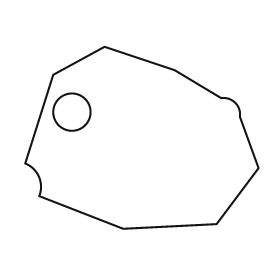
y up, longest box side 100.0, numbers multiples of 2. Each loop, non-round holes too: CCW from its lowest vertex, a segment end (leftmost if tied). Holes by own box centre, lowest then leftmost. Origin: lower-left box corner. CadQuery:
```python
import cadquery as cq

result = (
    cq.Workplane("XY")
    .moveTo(42.0, 0.0)
    .lineTo(82.0, 2.0)
    .lineTo(100.0, 26.0)
    .lineTo(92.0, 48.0)
    .threePointArc((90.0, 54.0), (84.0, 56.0))
    .lineTo(64.0, 68.0)
    .lineTo(34.0, 78.0)
    .lineTo(12.0, 66.0)
    .lineTo(0.0, 28.0)
    .threePointArc((6.0, 22.0), (6.0, 14.0))
    .close()
    .moveTo(20.0, 50.0)
    .circle(8.0)
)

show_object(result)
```